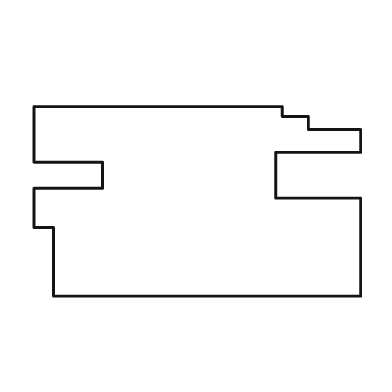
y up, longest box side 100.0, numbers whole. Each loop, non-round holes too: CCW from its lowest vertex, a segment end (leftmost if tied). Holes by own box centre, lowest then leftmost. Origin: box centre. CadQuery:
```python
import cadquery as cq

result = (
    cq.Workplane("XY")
    .moveTo(-44.0, -29.0)
    .lineTo(50.0, -29.0)
    .lineTo(50.0, 1.0)
    .lineTo(24.0, 1.0)
    .lineTo(24.0, 15.0)
    .lineTo(50.0, 15.0)
    .lineTo(50.0, 22.0)
    .lineTo(34.0, 22.0)
    .lineTo(34.0, 26.0)
    .lineTo(26.0, 26.0)
    .lineTo(26.0, 29.0)
    .lineTo(-50.0, 29.0)
    .lineTo(-50.0, 12.0)
    .lineTo(-29.0, 12.0)
    .lineTo(-29.0, 4.0)
    .lineTo(-50.0, 4.0)
    .lineTo(-50.0, -8.0)
    .lineTo(-44.0, -8.0)
    .close()
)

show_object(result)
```